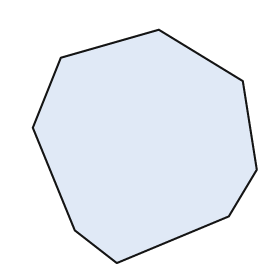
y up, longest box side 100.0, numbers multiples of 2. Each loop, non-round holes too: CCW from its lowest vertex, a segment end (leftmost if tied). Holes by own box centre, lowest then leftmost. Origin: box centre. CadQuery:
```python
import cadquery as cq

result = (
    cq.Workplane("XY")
    .moveTo(-12.0, -50.0)
    .lineTo(36.0, -30.0)
    .lineTo(48.0, -10.0)
    .lineTo(42.0, 28.0)
    .lineTo(6.0, 50.0)
    .lineTo(-36.0, 38.0)
    .lineTo(-48.0, 8.0)
    .lineTo(-30.0, -36.0)
    .close()
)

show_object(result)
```